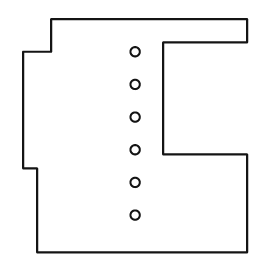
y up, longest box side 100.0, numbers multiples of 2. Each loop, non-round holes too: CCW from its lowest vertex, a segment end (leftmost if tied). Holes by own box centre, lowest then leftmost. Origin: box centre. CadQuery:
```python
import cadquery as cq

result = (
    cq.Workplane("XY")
    .moveTo(-42.0, -50.0)
    .lineTo(48.0, -50.0)
    .lineTo(48.0, -8.0)
    .lineTo(12.0, -8.0)
    .lineTo(12.0, 40.0)
    .lineTo(48.0, 40.0)
    .lineTo(48.0, 50.0)
    .lineTo(-36.0, 50.0)
    .lineTo(-36.0, 36.0)
    .lineTo(-48.0, 36.0)
    .lineTo(-48.0, -14.0)
    .lineTo(-42.0, -14.0)
    .close()
    .moveTo(0.0, -34.0)
    .circle(2.0)
    .moveTo(0.0, -20.0)
    .circle(2.0)
    .moveTo(0.0, -6.0)
    .circle(2.0)
    .moveTo(0.0, 8.0)
    .circle(2.0)
    .moveTo(0.0, 22.0)
    .circle(2.0)
    .moveTo(0.0, 36.0)
    .circle(2.0)
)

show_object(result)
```